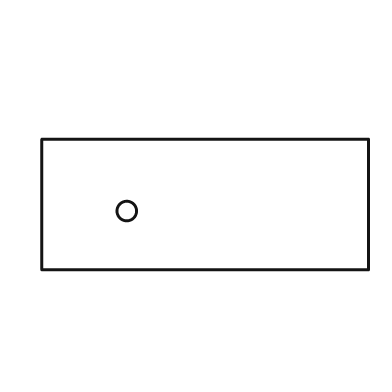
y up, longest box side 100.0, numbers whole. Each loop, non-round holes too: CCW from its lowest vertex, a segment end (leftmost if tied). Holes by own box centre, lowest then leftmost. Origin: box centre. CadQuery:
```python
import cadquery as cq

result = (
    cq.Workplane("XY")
    .moveTo(-50.0, -20.0)
    .lineTo(50.0, -20.0)
    .lineTo(50.0, 20.0)
    .lineTo(-50.0, 20.0)
    .close()
    .moveTo(-24.0, -2.0)
    .circle(3.0)
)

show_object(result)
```